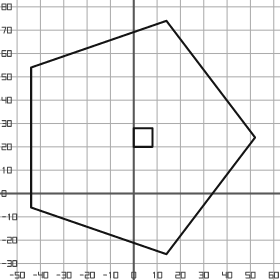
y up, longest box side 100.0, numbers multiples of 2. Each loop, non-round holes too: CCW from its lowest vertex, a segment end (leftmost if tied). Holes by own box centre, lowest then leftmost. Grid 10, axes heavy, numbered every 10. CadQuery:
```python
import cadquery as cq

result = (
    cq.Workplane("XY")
    .moveTo(14.0, -26.0)
    .lineTo(52.0, 24.0)
    .lineTo(14.0, 74.0)
    .lineTo(-44.0, 54.0)
    .lineTo(-44.0, -6.0)
    .close()
    .moveTo(0.0, 20.0)
    .lineTo(8.0, 20.0)
    .lineTo(8.0, 28.0)
    .lineTo(0.0, 28.0)
    .close()
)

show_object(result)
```